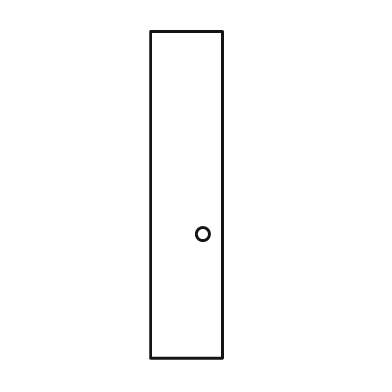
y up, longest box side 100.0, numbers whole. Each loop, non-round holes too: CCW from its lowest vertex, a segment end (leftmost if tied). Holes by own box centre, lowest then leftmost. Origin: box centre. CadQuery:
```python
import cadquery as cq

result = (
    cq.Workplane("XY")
    .moveTo(-11.0, -50.0)
    .lineTo(11.0, -50.0)
    .lineTo(11.0, 50.0)
    .lineTo(-11.0, 50.0)
    .close()
    .moveTo(5.0, -12.0)
    .circle(2.0)
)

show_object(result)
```